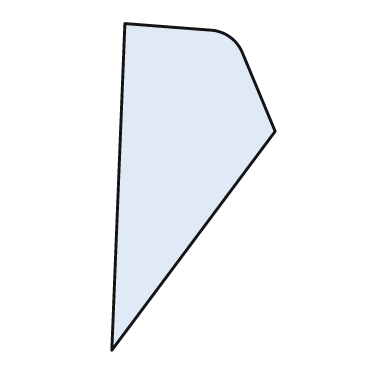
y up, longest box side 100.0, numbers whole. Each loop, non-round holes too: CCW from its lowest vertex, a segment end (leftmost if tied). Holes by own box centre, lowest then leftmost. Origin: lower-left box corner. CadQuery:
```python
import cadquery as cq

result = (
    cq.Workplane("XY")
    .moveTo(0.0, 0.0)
    .lineTo(50.0, 67.0)
    .lineTo(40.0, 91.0)
    .threePointArc((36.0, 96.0), (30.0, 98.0))
    .lineTo(4.0, 100.0)
    .close()
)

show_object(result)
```